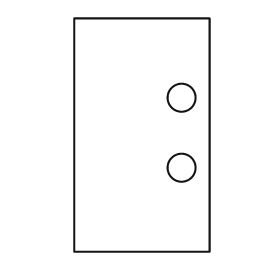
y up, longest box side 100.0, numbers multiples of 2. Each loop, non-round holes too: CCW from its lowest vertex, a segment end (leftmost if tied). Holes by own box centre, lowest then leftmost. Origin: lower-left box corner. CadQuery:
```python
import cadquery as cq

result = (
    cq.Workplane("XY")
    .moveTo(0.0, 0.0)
    .lineTo(58.0, 0.0)
    .lineTo(58.0, 100.0)
    .lineTo(0.0, 100.0)
    .close()
    .moveTo(46.0, 36.0)
    .circle(6.0)
    .moveTo(46.0, 66.0)
    .circle(6.0)
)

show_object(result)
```